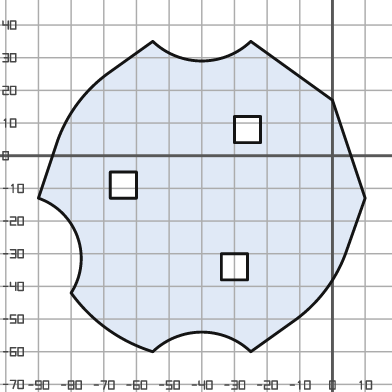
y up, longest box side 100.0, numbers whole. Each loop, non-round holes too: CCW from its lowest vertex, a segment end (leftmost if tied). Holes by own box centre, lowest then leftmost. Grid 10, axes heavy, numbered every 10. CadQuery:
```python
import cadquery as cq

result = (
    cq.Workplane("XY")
    .moveTo(-55.0, -60.0)
    .threePointArc((-40.0, -54.0), (-25.0, -60.0))
    .lineTo(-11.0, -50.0)
    .threePointArc((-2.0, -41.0), (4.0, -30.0))
    .lineTo(10.0, -13.0)
    .lineTo(0.0, 17.0)
    .lineTo(-25.0, 35.0)
    .threePointArc((-40.0, 29.0), (-55.0, 35.0))
    .lineTo(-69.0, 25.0)
    .threePointArc((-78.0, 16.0), (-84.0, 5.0))
    .lineTo(-90.0, -13.0)
    .threePointArc((-78.0, -25.0), (-80.0, -42.0))
    .threePointArc((-69.0, -53.0), (-55.0, -60.0))
    .close()
    .moveTo(-34.0, -38.0)
    .lineTo(-26.0, -38.0)
    .lineTo(-26.0, -30.0)
    .lineTo(-34.0, -30.0)
    .close()
    .moveTo(-68.0, -13.0)
    .lineTo(-60.0, -13.0)
    .lineTo(-60.0, -5.0)
    .lineTo(-68.0, -5.0)
    .close()
    .moveTo(-30.0, 4.0)
    .lineTo(-22.0, 4.0)
    .lineTo(-22.0, 12.0)
    .lineTo(-30.0, 12.0)
    .close()
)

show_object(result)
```